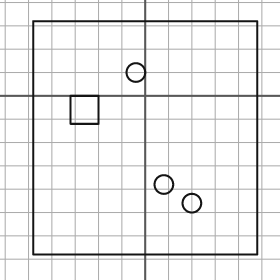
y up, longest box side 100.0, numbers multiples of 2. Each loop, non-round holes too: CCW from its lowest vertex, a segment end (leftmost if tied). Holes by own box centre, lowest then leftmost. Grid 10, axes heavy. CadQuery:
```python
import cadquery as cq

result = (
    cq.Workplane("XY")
    .moveTo(-48.0, -68.0)
    .lineTo(48.0, -68.0)
    .lineTo(48.0, 32.0)
    .lineTo(-48.0, 32.0)
    .close()
    .moveTo(20.0, -46.0)
    .circle(4.0)
    .moveTo(8.0, -38.0)
    .circle(4.0)
    .moveTo(-32.0, -12.0)
    .lineTo(-20.0, -12.0)
    .lineTo(-20.0, 0.0)
    .lineTo(-32.0, 0.0)
    .close()
    .moveTo(-4.0, 10.0)
    .circle(4.0)
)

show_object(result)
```